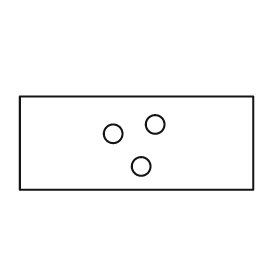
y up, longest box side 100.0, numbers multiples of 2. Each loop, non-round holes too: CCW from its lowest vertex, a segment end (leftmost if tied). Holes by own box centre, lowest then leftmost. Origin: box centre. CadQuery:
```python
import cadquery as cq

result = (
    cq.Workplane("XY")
    .moveTo(-50.0, -20.0)
    .lineTo(50.0, -20.0)
    .lineTo(50.0, 20.0)
    .lineTo(-50.0, 20.0)
    .close()
    .moveTo(2.0, -10.0)
    .circle(4.0)
    .moveTo(-10.0, 4.0)
    .circle(4.0)
    .moveTo(8.0, 8.0)
    .circle(4.0)
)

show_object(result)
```